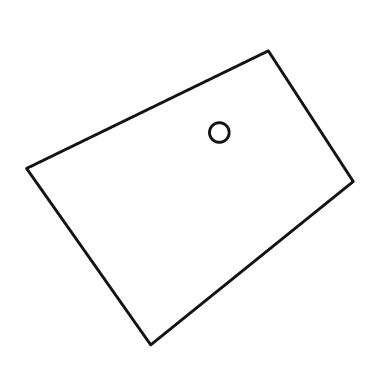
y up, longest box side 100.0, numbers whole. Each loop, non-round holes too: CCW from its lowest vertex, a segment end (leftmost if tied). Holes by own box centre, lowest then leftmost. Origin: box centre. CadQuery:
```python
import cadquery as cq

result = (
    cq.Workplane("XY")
    .moveTo(-12.0, -45.0)
    .lineTo(50.0, 5.0)
    .lineTo(24.0, 45.0)
    .lineTo(-50.0, 9.0)
    .close()
    .moveTo(9.0, 20.0)
    .circle(3.0)
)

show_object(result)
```